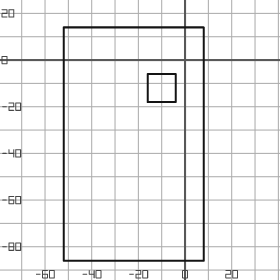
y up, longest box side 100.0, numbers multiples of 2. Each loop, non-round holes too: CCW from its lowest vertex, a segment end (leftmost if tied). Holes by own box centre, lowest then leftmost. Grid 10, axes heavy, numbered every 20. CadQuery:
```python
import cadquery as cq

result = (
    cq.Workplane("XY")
    .moveTo(-52.0, -86.0)
    .lineTo(8.0, -86.0)
    .lineTo(8.0, 14.0)
    .lineTo(-52.0, 14.0)
    .close()
    .moveTo(-16.0, -18.0)
    .lineTo(-4.0, -18.0)
    .lineTo(-4.0, -6.0)
    .lineTo(-16.0, -6.0)
    .close()
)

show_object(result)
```